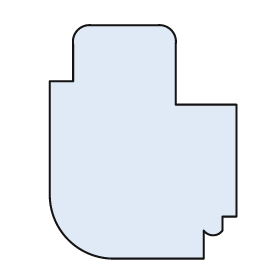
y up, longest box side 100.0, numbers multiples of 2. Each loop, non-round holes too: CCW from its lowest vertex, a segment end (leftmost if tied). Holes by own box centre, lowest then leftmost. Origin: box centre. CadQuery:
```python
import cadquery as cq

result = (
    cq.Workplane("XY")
    .moveTo(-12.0, -50.0)
    .lineTo(26.0, -50.0)
    .lineTo(26.0, -38.0)
    .threePointArc((30.0, -40.0), (34.0, -38.0))
    .lineTo(34.0, -32.0)
    .lineTo(40.0, -32.0)
    .lineTo(40.0, 16.0)
    .lineTo(14.0, 16.0)
    .lineTo(14.0, 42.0)
    .threePointArc((12.0, 48.0), (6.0, 50.0))
    .lineTo(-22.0, 50.0)
    .threePointArc((-28.0, 48.0), (-30.0, 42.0))
    .lineTo(-30.0, 26.0)
    .lineTo(-40.0, 26.0)
    .lineTo(-40.0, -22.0)
    .threePointArc((-32.0, -42.0), (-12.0, -50.0))
    .close()
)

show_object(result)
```